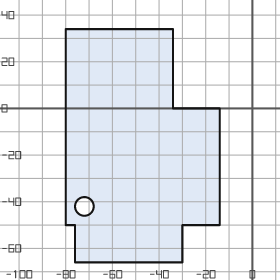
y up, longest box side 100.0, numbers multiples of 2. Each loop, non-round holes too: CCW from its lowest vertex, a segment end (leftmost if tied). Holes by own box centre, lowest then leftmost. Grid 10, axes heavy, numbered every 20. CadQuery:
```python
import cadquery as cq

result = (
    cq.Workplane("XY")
    .moveTo(-76.0, -66.0)
    .lineTo(-30.0, -66.0)
    .lineTo(-30.0, -50.0)
    .lineTo(-14.0, -50.0)
    .lineTo(-14.0, 0.0)
    .lineTo(-34.0, 0.0)
    .lineTo(-34.0, 34.0)
    .lineTo(-80.0, 34.0)
    .lineTo(-80.0, -50.0)
    .lineTo(-76.0, -50.0)
    .close()
    .moveTo(-72.0, -42.0)
    .circle(4.0)
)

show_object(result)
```